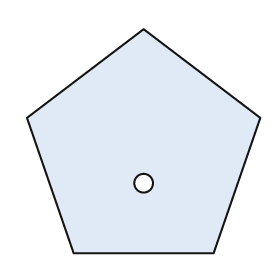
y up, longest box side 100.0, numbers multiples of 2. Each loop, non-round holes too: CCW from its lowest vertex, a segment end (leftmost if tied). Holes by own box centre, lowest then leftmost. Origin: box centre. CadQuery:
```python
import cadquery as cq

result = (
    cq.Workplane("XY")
    .moveTo(-30.0, -48.0)
    .lineTo(30.0, -48.0)
    .lineTo(50.0, 10.0)
    .lineTo(0.0, 48.0)
    .lineTo(-50.0, 10.0)
    .close()
    .moveTo(0.0, -18.0)
    .circle(4.0)
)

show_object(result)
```